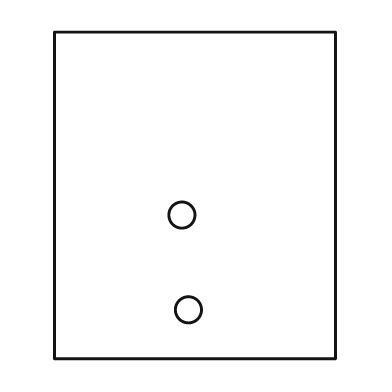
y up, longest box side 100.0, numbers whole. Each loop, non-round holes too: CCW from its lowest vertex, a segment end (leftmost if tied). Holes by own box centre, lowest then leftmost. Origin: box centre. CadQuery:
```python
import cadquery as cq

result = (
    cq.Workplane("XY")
    .moveTo(-43.0, -50.0)
    .lineTo(43.0, -50.0)
    .lineTo(43.0, 50.0)
    .lineTo(-43.0, 50.0)
    .close()
    .moveTo(-2.0, -35.0)
    .circle(4.0)
    .moveTo(-4.0, -6.0)
    .circle(4.0)
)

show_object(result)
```